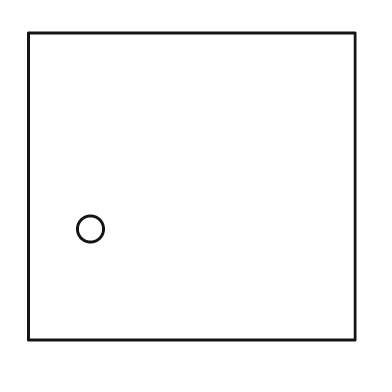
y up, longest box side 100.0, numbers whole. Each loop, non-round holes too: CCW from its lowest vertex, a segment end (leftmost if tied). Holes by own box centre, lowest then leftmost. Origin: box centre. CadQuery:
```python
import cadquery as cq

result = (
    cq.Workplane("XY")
    .moveTo(-50.0, -47.0)
    .lineTo(50.0, -47.0)
    .lineTo(50.0, 47.0)
    .lineTo(-50.0, 47.0)
    .close()
    .moveTo(-31.0, -13.0)
    .circle(4.0)
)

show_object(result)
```